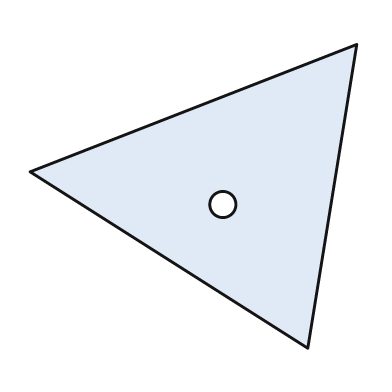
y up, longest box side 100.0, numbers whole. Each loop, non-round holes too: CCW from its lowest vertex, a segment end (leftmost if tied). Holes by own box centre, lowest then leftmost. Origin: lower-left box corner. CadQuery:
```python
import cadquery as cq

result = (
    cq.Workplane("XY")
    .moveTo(85.0, 0.0)
    .lineTo(100.0, 93.0)
    .lineTo(0.0, 54.0)
    .close()
    .moveTo(59.0, 44.0)
    .circle(4.0)
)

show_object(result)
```